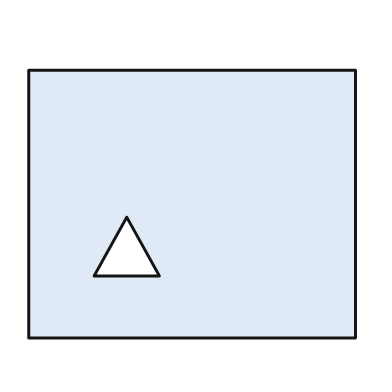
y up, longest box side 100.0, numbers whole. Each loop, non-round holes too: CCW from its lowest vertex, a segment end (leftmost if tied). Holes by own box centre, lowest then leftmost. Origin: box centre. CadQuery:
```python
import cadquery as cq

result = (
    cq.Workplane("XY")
    .moveTo(-50.0, -41.0)
    .lineTo(50.0, -41.0)
    .lineTo(50.0, 41.0)
    .lineTo(-50.0, 41.0)
    .close()
    .moveTo(-30.0, -22.0)
    .lineTo(-10.0, -22.0)
    .lineTo(-20.0, -4.0)
    .close()
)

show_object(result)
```